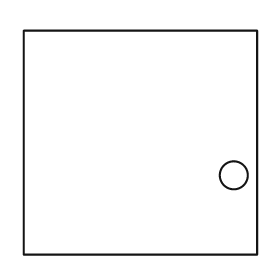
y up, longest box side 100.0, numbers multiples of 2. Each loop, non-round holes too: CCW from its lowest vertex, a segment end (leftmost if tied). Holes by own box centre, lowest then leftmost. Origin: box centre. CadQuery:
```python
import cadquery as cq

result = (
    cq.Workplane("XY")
    .moveTo(-50.0, -48.0)
    .lineTo(50.0, -48.0)
    .lineTo(50.0, 48.0)
    .lineTo(-50.0, 48.0)
    .close()
    .moveTo(40.0, -14.0)
    .circle(6.0)
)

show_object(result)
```